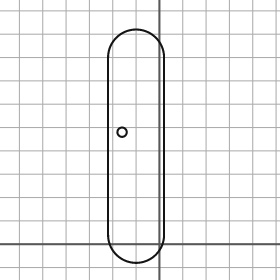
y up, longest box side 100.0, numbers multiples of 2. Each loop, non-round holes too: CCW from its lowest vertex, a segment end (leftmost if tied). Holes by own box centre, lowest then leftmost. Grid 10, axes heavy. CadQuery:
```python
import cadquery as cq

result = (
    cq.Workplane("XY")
    .moveTo(-22.0, 4.0)
    .threePointArc((-10.0, -8.0), (2.0, 4.0))
    .lineTo(2.0, 80.0)
    .threePointArc((-10.0, 92.0), (-22.0, 80.0))
    .close()
    .moveTo(-16.0, 48.0)
    .circle(2.0)
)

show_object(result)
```